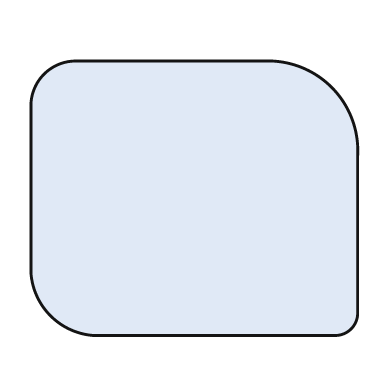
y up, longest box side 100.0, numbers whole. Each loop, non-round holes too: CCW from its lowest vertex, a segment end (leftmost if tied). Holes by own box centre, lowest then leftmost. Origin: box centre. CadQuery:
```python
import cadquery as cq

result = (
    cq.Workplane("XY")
    .moveTo(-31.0, -42.0)
    .lineTo(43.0, -42.0)
    .threePointArc((48.0, -40.0), (50.0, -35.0))
    .lineTo(50.0, 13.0)
    .threePointArc((42.0, 34.0), (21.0, 42.0))
    .lineTo(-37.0, 42.0)
    .threePointArc((-46.0, 38.0), (-50.0, 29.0))
    .lineTo(-50.0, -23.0)
    .threePointArc((-44.0, -36.0), (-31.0, -42.0))
    .close()
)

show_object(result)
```